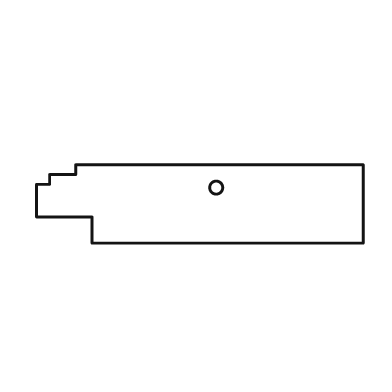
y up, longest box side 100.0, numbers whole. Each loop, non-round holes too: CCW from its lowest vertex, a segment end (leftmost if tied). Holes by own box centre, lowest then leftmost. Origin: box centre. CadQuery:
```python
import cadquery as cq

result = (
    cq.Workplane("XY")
    .moveTo(-33.0, -12.0)
    .lineTo(50.0, -12.0)
    .lineTo(50.0, 12.0)
    .lineTo(-38.0, 12.0)
    .lineTo(-38.0, 9.0)
    .lineTo(-46.0, 9.0)
    .lineTo(-46.0, 6.0)
    .lineTo(-50.0, 6.0)
    .lineTo(-50.0, -4.0)
    .lineTo(-33.0, -4.0)
    .close()
    .moveTo(5.0, 5.0)
    .circle(2.0)
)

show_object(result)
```